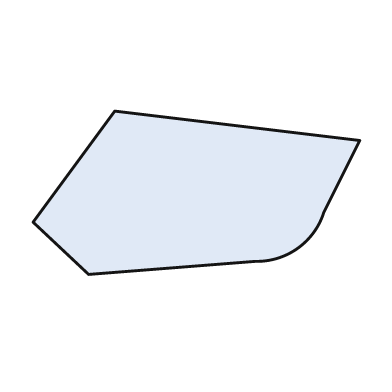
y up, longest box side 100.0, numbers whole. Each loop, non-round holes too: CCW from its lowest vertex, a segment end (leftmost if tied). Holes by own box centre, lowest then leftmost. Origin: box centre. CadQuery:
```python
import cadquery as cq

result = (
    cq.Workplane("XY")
    .moveTo(-33.0, -25.0)
    .lineTo(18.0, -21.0)
    .threePointArc((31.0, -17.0), (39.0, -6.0))
    .lineTo(50.0, 16.0)
    .lineTo(-25.0, 25.0)
    .lineTo(-50.0, -9.0)
    .close()
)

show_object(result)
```